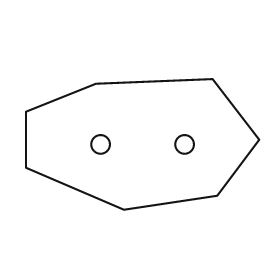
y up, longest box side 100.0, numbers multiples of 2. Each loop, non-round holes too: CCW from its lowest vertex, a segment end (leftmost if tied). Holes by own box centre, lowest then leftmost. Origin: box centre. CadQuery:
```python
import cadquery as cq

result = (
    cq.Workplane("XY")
    .moveTo(-8.0, -28.0)
    .lineTo(32.0, -22.0)
    .lineTo(50.0, 2.0)
    .lineTo(30.0, 28.0)
    .lineTo(-20.0, 26.0)
    .lineTo(-50.0, 14.0)
    .lineTo(-50.0, -10.0)
    .close()
    .moveTo(-18.0, 0.0)
    .circle(4.0)
    .moveTo(18.0, 0.0)
    .circle(4.0)
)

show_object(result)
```